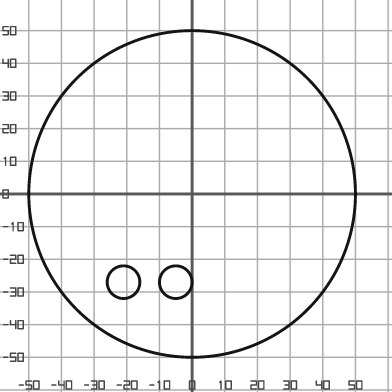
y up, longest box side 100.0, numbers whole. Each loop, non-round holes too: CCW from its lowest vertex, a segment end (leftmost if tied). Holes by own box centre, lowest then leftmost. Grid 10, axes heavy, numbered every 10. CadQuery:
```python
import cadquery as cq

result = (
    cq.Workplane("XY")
    .moveTo(0.0, 0.0)
    .circle(50.0)
    .moveTo(-21.0, -27.0)
    .circle(5.0)
    .moveTo(-5.0, -27.0)
    .circle(5.0)
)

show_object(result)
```